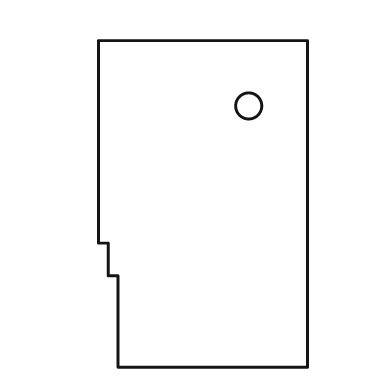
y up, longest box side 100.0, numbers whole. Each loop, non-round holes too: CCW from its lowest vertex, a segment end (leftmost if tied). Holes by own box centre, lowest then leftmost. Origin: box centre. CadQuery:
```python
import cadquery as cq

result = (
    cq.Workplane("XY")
    .moveTo(-26.0, -50.0)
    .lineTo(32.0, -50.0)
    .lineTo(32.0, 50.0)
    .lineTo(-32.0, 50.0)
    .lineTo(-32.0, -12.0)
    .lineTo(-29.0, -12.0)
    .lineTo(-29.0, -22.0)
    .lineTo(-26.0, -22.0)
    .close()
    .moveTo(14.0, 30.0)
    .circle(4.0)
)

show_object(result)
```